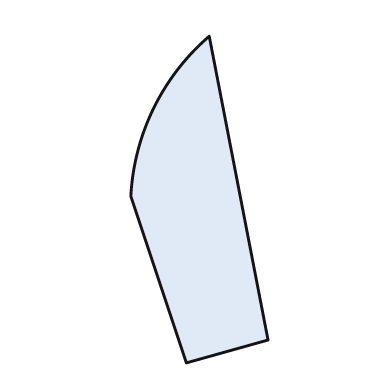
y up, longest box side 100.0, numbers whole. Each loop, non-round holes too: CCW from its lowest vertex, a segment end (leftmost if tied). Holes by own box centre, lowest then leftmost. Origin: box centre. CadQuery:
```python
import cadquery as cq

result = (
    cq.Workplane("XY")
    .moveTo(-4.0, -50.0)
    .lineTo(21.0, -43.0)
    .lineTo(3.0, 50.0)
    .threePointArc((-14.0, 28.0), (-21.0, 1.0))
    .close()
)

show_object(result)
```